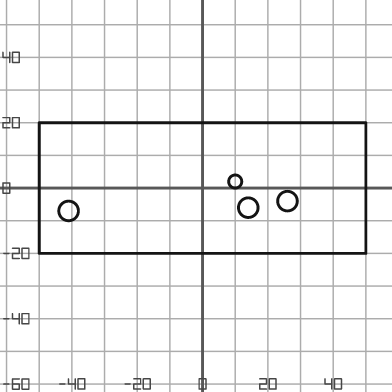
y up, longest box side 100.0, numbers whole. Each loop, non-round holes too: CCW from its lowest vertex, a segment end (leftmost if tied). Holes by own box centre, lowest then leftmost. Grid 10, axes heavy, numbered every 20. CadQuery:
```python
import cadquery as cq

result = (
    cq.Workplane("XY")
    .moveTo(-50.0, -20.0)
    .lineTo(50.0, -20.0)
    .lineTo(50.0, 20.0)
    .lineTo(-50.0, 20.0)
    .close()
    .moveTo(-41.0, -7.0)
    .circle(3.0)
    .moveTo(14.0, -6.0)
    .circle(3.0)
    .moveTo(26.0, -4.0)
    .circle(3.0)
    .moveTo(10.0, 2.0)
    .circle(2.0)
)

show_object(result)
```